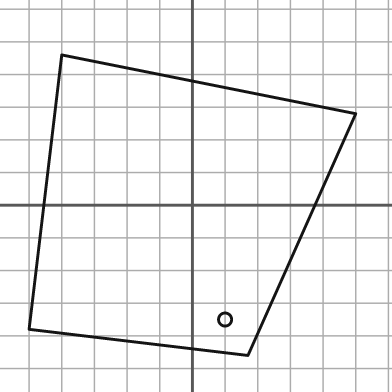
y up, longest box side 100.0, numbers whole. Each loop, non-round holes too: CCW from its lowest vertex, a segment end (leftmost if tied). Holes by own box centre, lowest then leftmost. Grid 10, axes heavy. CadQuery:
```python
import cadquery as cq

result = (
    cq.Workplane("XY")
    .moveTo(17.0, -46.0)
    .lineTo(50.0, 28.0)
    .lineTo(-40.0, 46.0)
    .lineTo(-50.0, -38.0)
    .close()
    .moveTo(10.0, -35.0)
    .circle(2.0)
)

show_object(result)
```